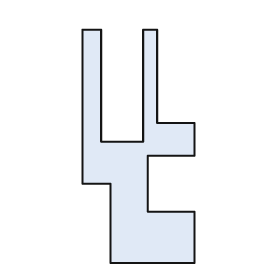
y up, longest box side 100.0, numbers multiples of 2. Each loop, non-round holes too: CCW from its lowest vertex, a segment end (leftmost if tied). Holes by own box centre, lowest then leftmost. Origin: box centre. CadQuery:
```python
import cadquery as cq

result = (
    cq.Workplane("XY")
    .moveTo(-12.0, -50.0)
    .lineTo(24.0, -50.0)
    .lineTo(24.0, -28.0)
    .lineTo(4.0, -28.0)
    .lineTo(4.0, -4.0)
    .lineTo(24.0, -4.0)
    .lineTo(24.0, 10.0)
    .lineTo(8.0, 10.0)
    .lineTo(8.0, 50.0)
    .lineTo(2.0, 50.0)
    .lineTo(2.0, 2.0)
    .lineTo(-16.0, 2.0)
    .lineTo(-16.0, 50.0)
    .lineTo(-24.0, 50.0)
    .lineTo(-24.0, -16.0)
    .lineTo(-12.0, -16.0)
    .close()
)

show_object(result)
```